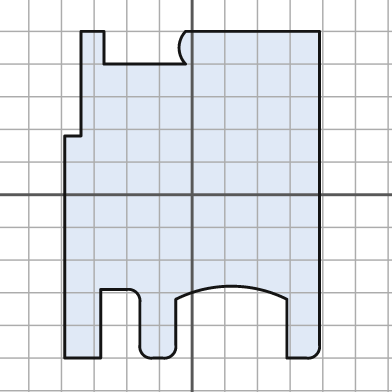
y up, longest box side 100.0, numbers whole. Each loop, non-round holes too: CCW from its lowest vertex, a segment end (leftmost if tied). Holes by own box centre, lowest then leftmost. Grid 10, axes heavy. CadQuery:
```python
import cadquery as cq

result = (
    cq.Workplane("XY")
    .moveTo(-39.0, -50.0)
    .lineTo(-28.0, -50.0)
    .lineTo(-28.0, -29.0)
    .lineTo(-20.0, -29.0)
    .threePointArc((-17.0, -30.0), (-16.0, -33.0))
    .lineTo(-16.0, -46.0)
    .threePointArc((-15.0, -49.0), (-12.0, -50.0))
    .lineTo(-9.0, -50.0)
    .threePointArc((-6.0, -49.0), (-5.0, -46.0))
    .lineTo(-5.0, -32.0)
    .threePointArc((12.0, -28.0), (29.0, -32.0))
    .lineTo(29.0, -50.0)
    .lineTo(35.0, -50.0)
    .threePointArc((38.0, -49.0), (39.0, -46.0))
    .lineTo(39.0, 50.0)
    .lineTo(-2.0, 50.0)
    .threePointArc((-4.0, 45.0), (-2.0, 40.0))
    .lineTo(-27.0, 40.0)
    .lineTo(-27.0, 50.0)
    .lineTo(-34.0, 50.0)
    .lineTo(-34.0, 18.0)
    .lineTo(-39.0, 18.0)
    .close()
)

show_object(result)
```